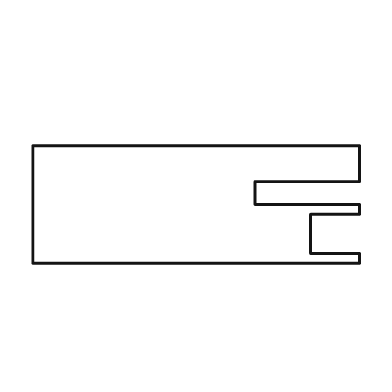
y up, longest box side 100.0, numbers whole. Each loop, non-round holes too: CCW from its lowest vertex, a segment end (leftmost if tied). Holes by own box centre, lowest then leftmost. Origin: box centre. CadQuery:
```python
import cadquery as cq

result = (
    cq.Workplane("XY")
    .moveTo(-50.0, -18.0)
    .lineTo(50.0, -18.0)
    .lineTo(50.0, -15.0)
    .lineTo(35.0, -15.0)
    .lineTo(35.0, -3.0)
    .lineTo(50.0, -3.0)
    .lineTo(50.0, 0.0)
    .lineTo(18.0, 0.0)
    .lineTo(18.0, 7.0)
    .lineTo(50.0, 7.0)
    .lineTo(50.0, 18.0)
    .lineTo(-50.0, 18.0)
    .close()
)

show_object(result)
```